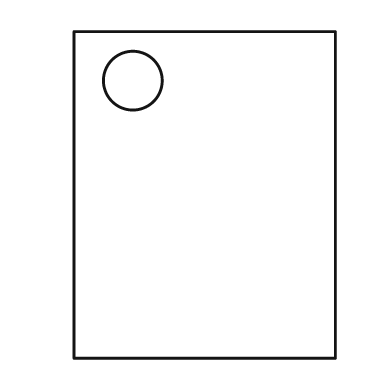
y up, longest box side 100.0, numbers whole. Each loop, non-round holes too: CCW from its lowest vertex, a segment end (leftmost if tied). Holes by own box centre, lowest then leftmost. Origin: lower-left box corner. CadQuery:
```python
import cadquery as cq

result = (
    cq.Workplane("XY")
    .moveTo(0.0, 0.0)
    .lineTo(80.0, 0.0)
    .lineTo(80.0, 100.0)
    .lineTo(0.0, 100.0)
    .close()
    .moveTo(18.0, 85.0)
    .circle(9.0)
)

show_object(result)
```